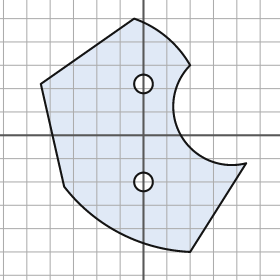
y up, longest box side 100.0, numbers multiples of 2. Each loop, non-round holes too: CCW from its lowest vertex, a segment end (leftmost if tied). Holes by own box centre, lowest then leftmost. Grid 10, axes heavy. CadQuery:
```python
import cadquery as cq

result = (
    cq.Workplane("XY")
    .moveTo(20.0, -50.0)
    .lineTo(44.0, -12.0)
    .threePointArc((16.0, 0.0), (20.0, 30.0))
    .threePointArc((10.0, 42.0), (-4.0, 50.0))
    .lineTo(-44.0, 22.0)
    .lineTo(-34.0, -22.0)
    .threePointArc((-10.0, -42.0), (20.0, -50.0))
    .close()
    .moveTo(0.0, -20.0)
    .circle(4.0)
    .moveTo(0.0, 22.0)
    .circle(4.0)
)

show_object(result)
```